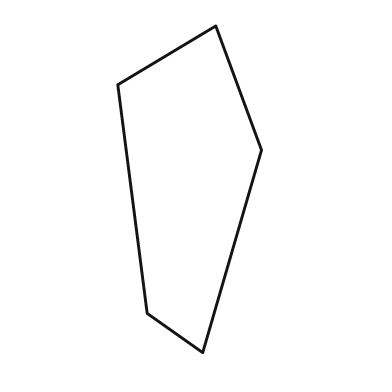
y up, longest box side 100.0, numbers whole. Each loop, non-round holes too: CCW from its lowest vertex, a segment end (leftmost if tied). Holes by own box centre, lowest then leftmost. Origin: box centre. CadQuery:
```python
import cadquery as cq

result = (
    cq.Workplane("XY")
    .moveTo(4.0, -50.0)
    .lineTo(22.0, 12.0)
    .lineTo(8.0, 50.0)
    .lineTo(-22.0, 32.0)
    .lineTo(-13.0, -38.0)
    .close()
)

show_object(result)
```